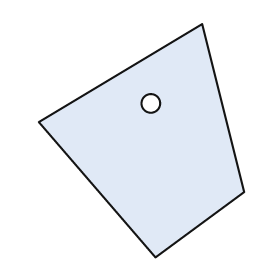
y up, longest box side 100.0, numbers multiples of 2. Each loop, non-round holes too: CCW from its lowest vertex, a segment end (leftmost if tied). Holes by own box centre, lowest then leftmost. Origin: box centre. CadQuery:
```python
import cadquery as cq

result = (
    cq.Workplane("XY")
    .moveTo(6.0, -50.0)
    .lineTo(44.0, -22.0)
    .lineTo(26.0, 50.0)
    .lineTo(-44.0, 8.0)
    .close()
    .moveTo(4.0, 16.0)
    .circle(4.0)
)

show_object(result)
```